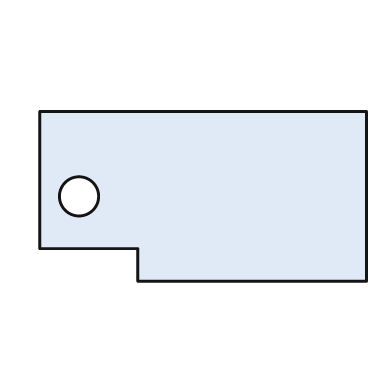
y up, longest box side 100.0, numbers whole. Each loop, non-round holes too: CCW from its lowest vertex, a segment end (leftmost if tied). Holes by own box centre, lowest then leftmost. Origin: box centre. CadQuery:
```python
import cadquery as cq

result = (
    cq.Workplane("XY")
    .moveTo(-20.0, -26.0)
    .lineTo(50.0, -26.0)
    .lineTo(50.0, 26.0)
    .lineTo(-50.0, 26.0)
    .lineTo(-50.0, -16.0)
    .lineTo(-20.0, -16.0)
    .close()
    .moveTo(-38.0, 0.0)
    .circle(6.0)
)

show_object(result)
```